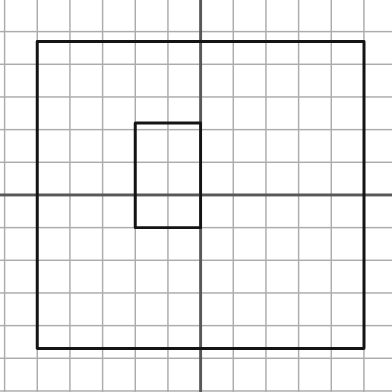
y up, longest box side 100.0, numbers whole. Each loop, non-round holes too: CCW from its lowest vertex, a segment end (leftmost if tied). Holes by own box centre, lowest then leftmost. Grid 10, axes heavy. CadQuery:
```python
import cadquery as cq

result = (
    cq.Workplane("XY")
    .moveTo(-50.0, -47.0)
    .lineTo(50.0, -47.0)
    .lineTo(50.0, 47.0)
    .lineTo(-50.0, 47.0)
    .close()
    .moveTo(-20.0, -10.0)
    .lineTo(0.0, -10.0)
    .lineTo(0.0, 22.0)
    .lineTo(-20.0, 22.0)
    .close()
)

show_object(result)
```